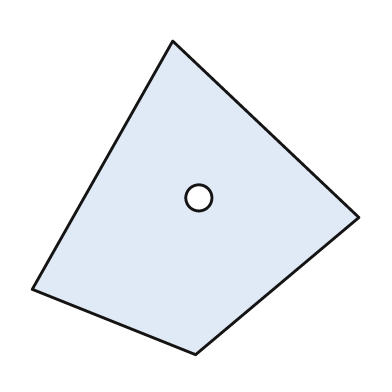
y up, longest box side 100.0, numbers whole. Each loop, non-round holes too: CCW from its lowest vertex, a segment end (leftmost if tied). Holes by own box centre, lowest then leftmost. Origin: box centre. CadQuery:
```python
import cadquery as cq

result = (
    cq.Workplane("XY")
    .moveTo(0.0, -48.0)
    .lineTo(50.0, -6.0)
    .lineTo(-7.0, 48.0)
    .lineTo(-50.0, -28.0)
    .close()
    .moveTo(1.0, 0.0)
    .circle(4.0)
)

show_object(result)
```